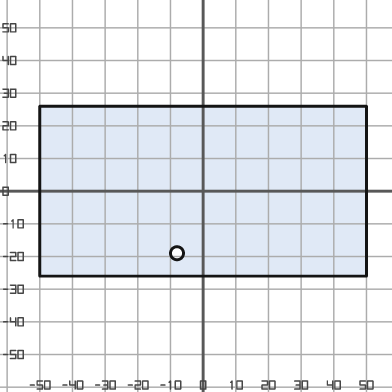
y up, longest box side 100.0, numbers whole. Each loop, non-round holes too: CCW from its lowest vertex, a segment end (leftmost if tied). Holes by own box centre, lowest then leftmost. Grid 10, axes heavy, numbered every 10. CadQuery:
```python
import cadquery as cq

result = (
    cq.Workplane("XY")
    .moveTo(-50.0, -26.0)
    .lineTo(50.0, -26.0)
    .lineTo(50.0, 26.0)
    .lineTo(-50.0, 26.0)
    .close()
    .moveTo(-8.0, -19.0)
    .circle(2.0)
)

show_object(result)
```